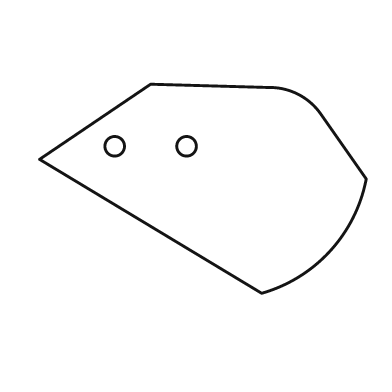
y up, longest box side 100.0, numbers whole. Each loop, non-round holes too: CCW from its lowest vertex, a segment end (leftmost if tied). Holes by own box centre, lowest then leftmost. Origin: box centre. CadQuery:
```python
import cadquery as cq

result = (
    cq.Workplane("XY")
    .moveTo(18.0, -32.0)
    .threePointArc((39.0, -19.0), (50.0, 3.0))
    .lineTo(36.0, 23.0)
    .threePointArc((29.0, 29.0), (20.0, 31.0))
    .lineTo(-16.0, 32.0)
    .lineTo(-50.0, 9.0)
    .close()
    .moveTo(-27.0, 13.0)
    .circle(3.0)
    .moveTo(-5.0, 13.0)
    .circle(3.0)
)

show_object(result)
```